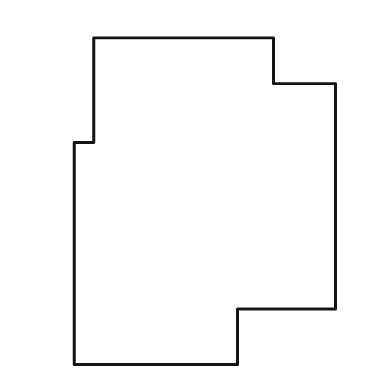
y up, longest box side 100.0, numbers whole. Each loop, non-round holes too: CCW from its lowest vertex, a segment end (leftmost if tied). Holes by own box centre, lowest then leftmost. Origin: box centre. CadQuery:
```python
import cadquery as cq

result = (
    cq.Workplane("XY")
    .moveTo(-40.0, -50.0)
    .lineTo(10.0, -50.0)
    .lineTo(10.0, -33.0)
    .lineTo(40.0, -33.0)
    .lineTo(40.0, 36.0)
    .lineTo(21.0, 36.0)
    .lineTo(21.0, 50.0)
    .lineTo(-34.0, 50.0)
    .lineTo(-34.0, 18.0)
    .lineTo(-40.0, 18.0)
    .close()
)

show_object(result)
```